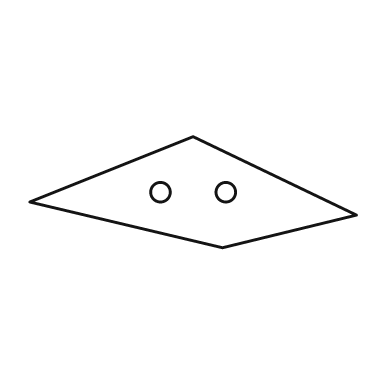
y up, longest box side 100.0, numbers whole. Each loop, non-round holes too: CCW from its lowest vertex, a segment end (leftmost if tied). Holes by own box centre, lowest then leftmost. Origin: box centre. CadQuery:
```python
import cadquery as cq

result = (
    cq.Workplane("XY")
    .moveTo(9.0, -17.0)
    .lineTo(50.0, -7.0)
    .lineTo(0.0, 17.0)
    .lineTo(-50.0, -3.0)
    .close()
    .moveTo(-10.0, 0.0)
    .circle(3.0)
    .moveTo(10.0, 0.0)
    .circle(3.0)
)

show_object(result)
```